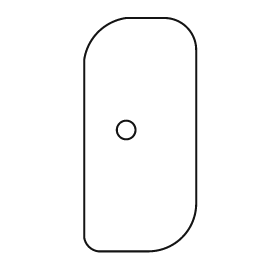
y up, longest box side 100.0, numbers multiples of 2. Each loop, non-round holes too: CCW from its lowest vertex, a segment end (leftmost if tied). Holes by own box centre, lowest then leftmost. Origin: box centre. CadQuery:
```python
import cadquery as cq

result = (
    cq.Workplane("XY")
    .moveTo(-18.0, -50.0)
    .lineTo(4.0, -50.0)
    .threePointArc((18.0, -44.0), (24.0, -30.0))
    .lineTo(24.0, 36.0)
    .threePointArc((20.0, 46.0), (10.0, 50.0))
    .lineTo(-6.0, 50.0)
    .threePointArc((-18.0, 44.0), (-24.0, 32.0))
    .lineTo(-24.0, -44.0)
    .threePointArc((-22.0, -48.0), (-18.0, -50.0))
    .close()
    .moveTo(-6.0, 2.0)
    .circle(4.0)
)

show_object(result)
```